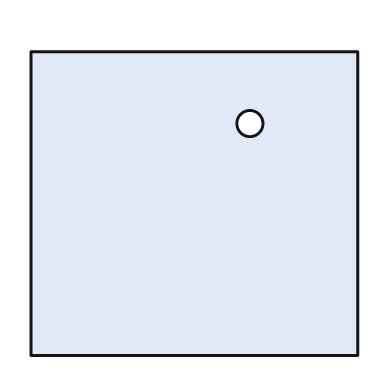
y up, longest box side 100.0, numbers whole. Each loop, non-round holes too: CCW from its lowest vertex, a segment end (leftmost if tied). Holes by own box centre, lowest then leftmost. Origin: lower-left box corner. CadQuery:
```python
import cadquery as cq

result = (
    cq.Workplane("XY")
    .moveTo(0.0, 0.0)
    .lineTo(100.0, 0.0)
    .lineTo(100.0, 93.0)
    .lineTo(0.0, 93.0)
    .close()
    .moveTo(67.0, 71.0)
    .circle(4.0)
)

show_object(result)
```